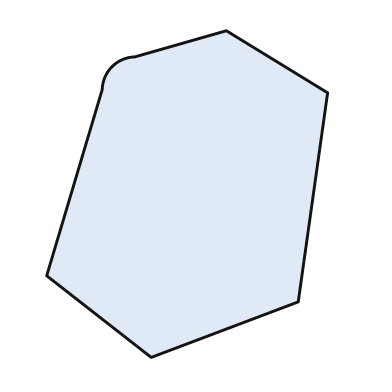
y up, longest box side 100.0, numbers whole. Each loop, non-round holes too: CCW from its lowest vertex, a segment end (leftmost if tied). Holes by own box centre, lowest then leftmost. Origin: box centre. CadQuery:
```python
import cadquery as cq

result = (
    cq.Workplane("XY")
    .moveTo(-11.0, -50.0)
    .lineTo(34.0, -33.0)
    .lineTo(43.0, 31.0)
    .lineTo(12.0, 50.0)
    .lineTo(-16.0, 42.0)
    .threePointArc((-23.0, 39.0), (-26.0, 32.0))
    .lineTo(-43.0, -25.0)
    .close()
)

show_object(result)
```